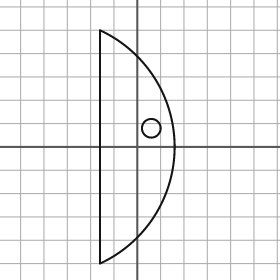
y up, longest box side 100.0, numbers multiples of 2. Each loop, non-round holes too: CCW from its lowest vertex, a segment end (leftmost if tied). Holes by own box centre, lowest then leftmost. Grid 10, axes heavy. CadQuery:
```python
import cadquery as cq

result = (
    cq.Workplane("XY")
    .moveTo(-16.0, -50.0)
    .threePointArc((16.0, 0.0), (-16.0, 50.0))
    .close()
    .moveTo(6.0, 8.0)
    .circle(4.0)
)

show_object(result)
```